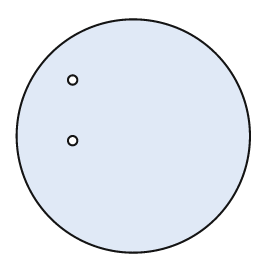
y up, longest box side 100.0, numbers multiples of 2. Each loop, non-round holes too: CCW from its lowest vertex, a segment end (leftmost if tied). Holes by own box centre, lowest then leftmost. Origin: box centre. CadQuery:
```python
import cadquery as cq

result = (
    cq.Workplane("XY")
    .moveTo(0.0, 0.0)
    .circle(50.0)
    .moveTo(-26.0, -2.0)
    .circle(2.0)
    .moveTo(-26.0, 24.0)
    .circle(2.0)
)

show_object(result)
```